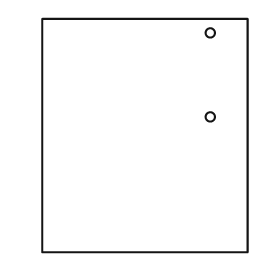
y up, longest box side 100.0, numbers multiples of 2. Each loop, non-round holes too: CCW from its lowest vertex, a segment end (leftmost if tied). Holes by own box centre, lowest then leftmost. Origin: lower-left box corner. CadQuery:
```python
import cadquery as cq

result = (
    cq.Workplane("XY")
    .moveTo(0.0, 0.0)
    .lineTo(88.0, 0.0)
    .lineTo(88.0, 100.0)
    .lineTo(0.0, 100.0)
    .close()
    .moveTo(72.0, 58.0)
    .circle(2.0)
    .moveTo(72.0, 94.0)
    .circle(2.0)
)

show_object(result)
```